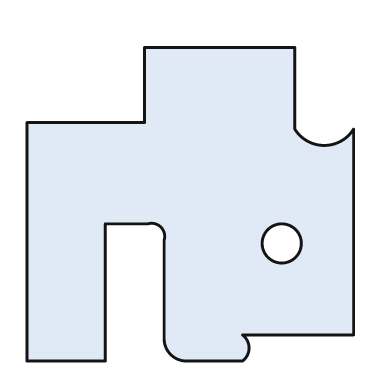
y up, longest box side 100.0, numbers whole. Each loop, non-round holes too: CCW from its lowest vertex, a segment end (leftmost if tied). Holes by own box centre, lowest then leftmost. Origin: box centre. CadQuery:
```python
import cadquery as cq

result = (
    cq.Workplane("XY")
    .moveTo(-50.0, -48.0)
    .lineTo(-26.0, -48.0)
    .lineTo(-26.0, -6.0)
    .lineTo(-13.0, -6.0)
    .threePointArc((-9.0, -7.0), (-8.0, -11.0))
    .lineTo(-8.0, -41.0)
    .threePointArc((-6.0, -46.0), (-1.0, -48.0))
    .lineTo(16.0, -48.0)
    .threePointArc((18.0, -44.0), (16.0, -40.0))
    .lineTo(50.0, -40.0)
    .lineTo(50.0, 23.0)
    .threePointArc((41.0, 18.0), (32.0, 23.0))
    .lineTo(32.0, 48.0)
    .lineTo(-14.0, 48.0)
    .lineTo(-14.0, 25.0)
    .lineTo(-50.0, 25.0)
    .close()
    .moveTo(28.0, -12.0)
    .circle(6.0)
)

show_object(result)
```